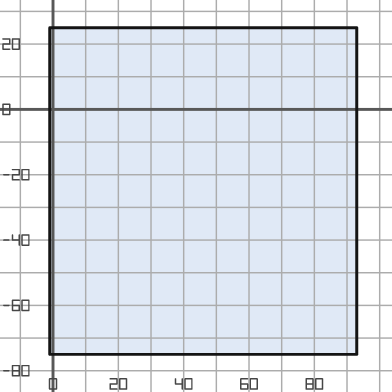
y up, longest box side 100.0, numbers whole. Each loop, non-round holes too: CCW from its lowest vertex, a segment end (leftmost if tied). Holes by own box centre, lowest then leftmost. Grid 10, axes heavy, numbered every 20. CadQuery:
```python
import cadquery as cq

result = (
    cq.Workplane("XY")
    .moveTo(-1.0, -75.0)
    .lineTo(93.0, -75.0)
    .lineTo(93.0, 25.0)
    .lineTo(-1.0, 25.0)
    .close()
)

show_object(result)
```